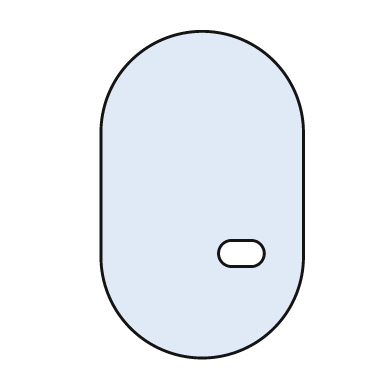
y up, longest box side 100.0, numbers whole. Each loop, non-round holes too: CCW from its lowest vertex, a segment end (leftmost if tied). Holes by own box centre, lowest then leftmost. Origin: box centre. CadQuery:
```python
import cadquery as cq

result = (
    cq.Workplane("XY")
    .moveTo(-31.0, -19.0)
    .threePointArc((0.0, -50.0), (31.0, -19.0))
    .lineTo(31.0, 19.0)
    .threePointArc((0.0, 50.0), (-31.0, 19.0))
    .close()
    .moveTo(9.0, -22.0)
    .lineTo(15.0, -22.0)
    .threePointArc((19.0, -18.0), (15.0, -14.0))
    .lineTo(9.0, -14.0)
    .threePointArc((5.0, -18.0), (9.0, -22.0))
    .close()
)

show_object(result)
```